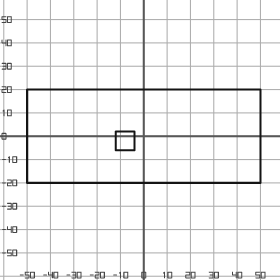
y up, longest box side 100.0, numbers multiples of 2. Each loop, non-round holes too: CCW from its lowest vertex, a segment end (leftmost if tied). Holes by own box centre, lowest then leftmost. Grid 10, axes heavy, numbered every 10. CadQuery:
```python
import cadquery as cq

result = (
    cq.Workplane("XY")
    .moveTo(-50.0, -20.0)
    .lineTo(50.0, -20.0)
    .lineTo(50.0, 20.0)
    .lineTo(-50.0, 20.0)
    .close()
    .moveTo(-12.0, -6.0)
    .lineTo(-4.0, -6.0)
    .lineTo(-4.0, 2.0)
    .lineTo(-12.0, 2.0)
    .close()
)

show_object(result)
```